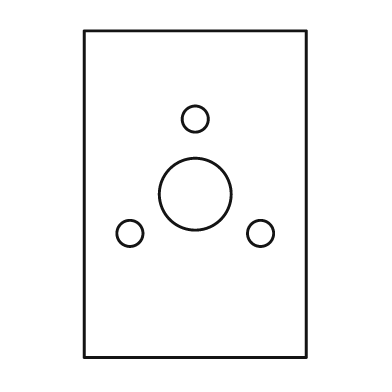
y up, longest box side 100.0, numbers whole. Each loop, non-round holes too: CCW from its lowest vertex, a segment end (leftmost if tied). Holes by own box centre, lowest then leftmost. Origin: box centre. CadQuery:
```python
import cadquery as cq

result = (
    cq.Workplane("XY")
    .moveTo(-34.0, -50.0)
    .lineTo(34.0, -50.0)
    .lineTo(34.0, 50.0)
    .lineTo(-34.0, 50.0)
    .close()
    .moveTo(-20.0, -12.0)
    .circle(4.0)
    .moveTo(20.0, -12.0)
    .circle(4.0)
    .moveTo(0.0, 0.0)
    .circle(11.0)
    .moveTo(0.0, 23.0)
    .circle(4.0)
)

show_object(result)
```